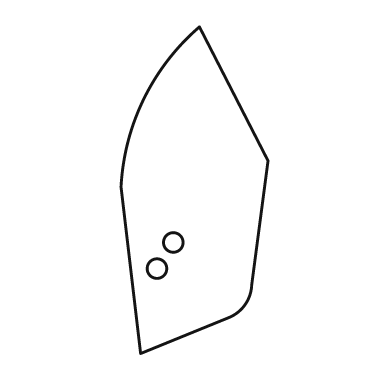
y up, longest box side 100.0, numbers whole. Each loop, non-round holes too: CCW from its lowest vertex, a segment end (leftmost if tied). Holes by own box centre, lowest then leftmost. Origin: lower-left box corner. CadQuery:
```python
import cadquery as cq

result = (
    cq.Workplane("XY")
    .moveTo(6.0, 0.0)
    .lineTo(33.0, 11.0)
    .threePointArc((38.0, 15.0), (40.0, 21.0))
    .lineTo(45.0, 59.0)
    .lineTo(24.0, 100.0)
    .threePointArc((7.0, 78.0), (0.0, 51.0))
    .close()
    .moveTo(11.0, 26.0)
    .circle(3.0)
    .moveTo(16.0, 34.0)
    .circle(3.0)
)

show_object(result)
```